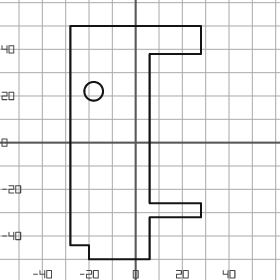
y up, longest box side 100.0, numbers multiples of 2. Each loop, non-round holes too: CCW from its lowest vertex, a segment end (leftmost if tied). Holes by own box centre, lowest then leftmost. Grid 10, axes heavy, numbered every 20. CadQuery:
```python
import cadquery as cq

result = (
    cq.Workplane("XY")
    .moveTo(-20.0, -50.0)
    .lineTo(6.0, -50.0)
    .lineTo(6.0, -32.0)
    .lineTo(28.0, -32.0)
    .lineTo(28.0, -26.0)
    .lineTo(6.0, -26.0)
    .lineTo(6.0, 38.0)
    .lineTo(28.0, 38.0)
    .lineTo(28.0, 50.0)
    .lineTo(-28.0, 50.0)
    .lineTo(-28.0, -44.0)
    .lineTo(-20.0, -44.0)
    .close()
    .moveTo(-18.0, 22.0)
    .circle(4.0)
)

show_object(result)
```